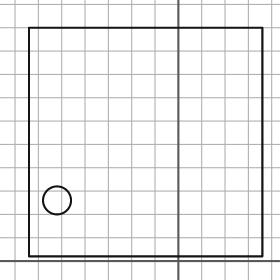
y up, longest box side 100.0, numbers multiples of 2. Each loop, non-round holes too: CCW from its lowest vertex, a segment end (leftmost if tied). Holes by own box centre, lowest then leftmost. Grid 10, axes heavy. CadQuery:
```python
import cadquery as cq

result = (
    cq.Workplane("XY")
    .moveTo(-64.0, 2.0)
    .lineTo(36.0, 2.0)
    .lineTo(36.0, 100.0)
    .lineTo(-64.0, 100.0)
    .close()
    .moveTo(-52.0, 26.0)
    .circle(6.0)
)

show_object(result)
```